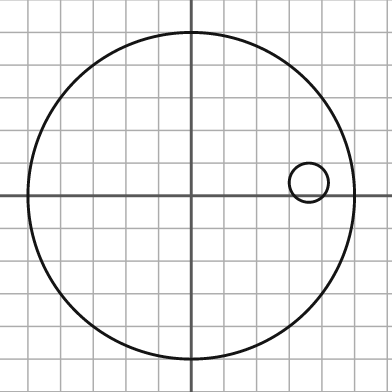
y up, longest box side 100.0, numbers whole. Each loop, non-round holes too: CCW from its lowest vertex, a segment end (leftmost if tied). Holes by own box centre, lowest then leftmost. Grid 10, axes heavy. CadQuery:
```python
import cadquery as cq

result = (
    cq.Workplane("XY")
    .moveTo(0.0, 0.0)
    .circle(50.0)
    .moveTo(36.0, 4.0)
    .circle(6.0)
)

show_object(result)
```